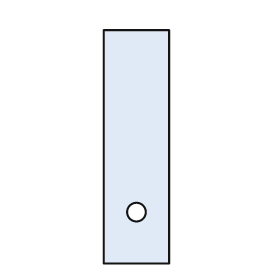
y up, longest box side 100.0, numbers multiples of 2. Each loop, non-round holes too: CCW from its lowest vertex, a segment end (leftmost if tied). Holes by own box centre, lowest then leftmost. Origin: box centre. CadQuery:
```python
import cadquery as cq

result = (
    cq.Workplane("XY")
    .moveTo(-14.0, -50.0)
    .lineTo(14.0, -50.0)
    .lineTo(14.0, 50.0)
    .lineTo(-14.0, 50.0)
    .close()
    .moveTo(0.0, -28.0)
    .circle(4.0)
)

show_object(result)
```